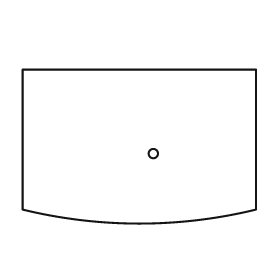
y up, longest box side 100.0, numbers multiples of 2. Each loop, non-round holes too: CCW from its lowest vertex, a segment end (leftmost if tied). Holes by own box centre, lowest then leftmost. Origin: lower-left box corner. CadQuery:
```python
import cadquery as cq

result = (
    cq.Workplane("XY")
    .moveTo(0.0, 6.0)
    .threePointArc((50.0, 0.0), (100.0, 6.0))
    .lineTo(100.0, 66.0)
    .lineTo(0.0, 66.0)
    .close()
    .moveTo(56.0, 30.0)
    .circle(2.0)
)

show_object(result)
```